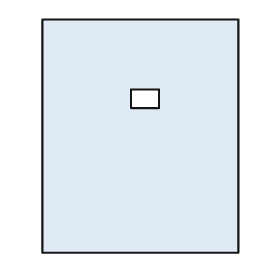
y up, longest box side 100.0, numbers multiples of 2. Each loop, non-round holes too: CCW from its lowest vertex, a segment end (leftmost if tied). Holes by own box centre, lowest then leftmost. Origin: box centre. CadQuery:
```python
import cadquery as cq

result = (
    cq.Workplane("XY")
    .moveTo(-42.0, -50.0)
    .lineTo(42.0, -50.0)
    .lineTo(42.0, 50.0)
    .lineTo(-42.0, 50.0)
    .close()
    .moveTo(-4.0, 12.0)
    .lineTo(8.0, 12.0)
    .lineTo(8.0, 20.0)
    .lineTo(-4.0, 20.0)
    .close()
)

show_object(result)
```